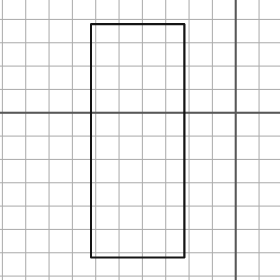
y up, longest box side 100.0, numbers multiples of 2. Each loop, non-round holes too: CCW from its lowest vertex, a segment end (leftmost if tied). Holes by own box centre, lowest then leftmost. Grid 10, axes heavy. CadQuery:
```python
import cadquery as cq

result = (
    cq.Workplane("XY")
    .moveTo(-62.0, -62.0)
    .lineTo(-22.0, -62.0)
    .lineTo(-22.0, 38.0)
    .lineTo(-62.0, 38.0)
    .close()
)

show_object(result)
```